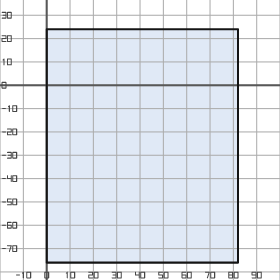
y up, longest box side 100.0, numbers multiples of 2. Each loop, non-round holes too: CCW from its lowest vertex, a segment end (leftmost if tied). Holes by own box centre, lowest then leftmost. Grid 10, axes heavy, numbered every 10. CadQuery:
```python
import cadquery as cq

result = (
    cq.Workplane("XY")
    .moveTo(0.0, -76.0)
    .lineTo(82.0, -76.0)
    .lineTo(82.0, 24.0)
    .lineTo(0.0, 24.0)
    .close()
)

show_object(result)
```